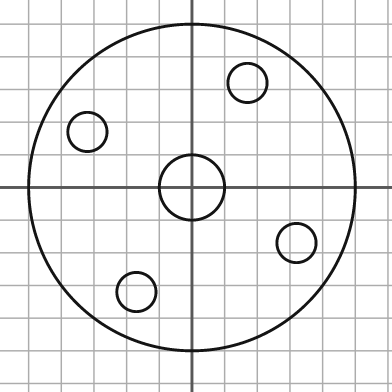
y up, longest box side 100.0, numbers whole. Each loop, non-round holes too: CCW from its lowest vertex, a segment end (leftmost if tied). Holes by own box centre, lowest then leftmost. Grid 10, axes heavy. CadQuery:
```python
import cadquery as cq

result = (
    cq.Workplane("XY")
    .moveTo(0.0, 0.0)
    .circle(50.0)
    .moveTo(-17.0, -32.0)
    .circle(6.0)
    .moveTo(32.0, -17.0)
    .circle(6.0)
    .moveTo(0.0, 0.0)
    .circle(10.0)
    .moveTo(-32.0, 17.0)
    .circle(6.0)
    .moveTo(17.0, 32.0)
    .circle(6.0)
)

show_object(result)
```